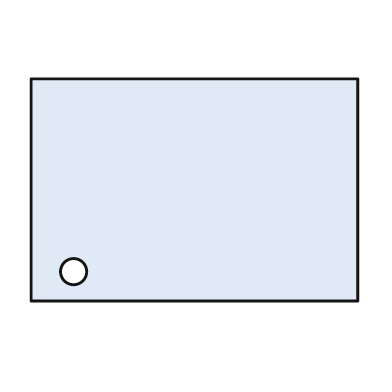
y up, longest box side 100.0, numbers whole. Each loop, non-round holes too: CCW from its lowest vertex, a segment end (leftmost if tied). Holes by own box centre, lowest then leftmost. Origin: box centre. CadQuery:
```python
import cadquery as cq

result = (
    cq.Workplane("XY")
    .moveTo(-50.0, -34.0)
    .lineTo(50.0, -34.0)
    .lineTo(50.0, 34.0)
    .lineTo(-50.0, 34.0)
    .close()
    .moveTo(-37.0, -25.0)
    .circle(4.0)
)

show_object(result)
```